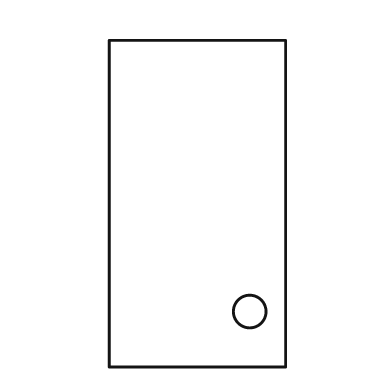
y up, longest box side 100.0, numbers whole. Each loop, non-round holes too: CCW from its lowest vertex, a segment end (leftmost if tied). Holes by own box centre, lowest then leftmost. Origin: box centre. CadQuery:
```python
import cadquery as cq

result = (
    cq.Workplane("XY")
    .moveTo(-27.0, -50.0)
    .lineTo(27.0, -50.0)
    .lineTo(27.0, 50.0)
    .lineTo(-27.0, 50.0)
    .close()
    .moveTo(16.0, -33.0)
    .circle(5.0)
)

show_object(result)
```